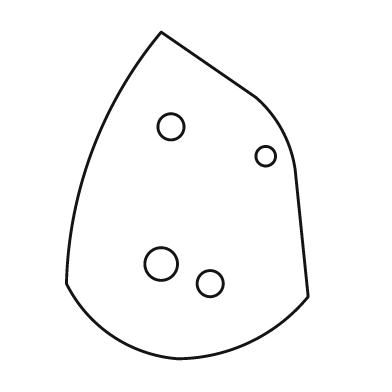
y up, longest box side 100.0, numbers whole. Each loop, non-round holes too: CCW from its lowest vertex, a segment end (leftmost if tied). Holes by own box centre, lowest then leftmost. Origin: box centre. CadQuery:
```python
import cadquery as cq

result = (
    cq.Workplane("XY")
    .moveTo(-3.0, -50.0)
    .threePointArc((19.0, -45.0), (37.0, -31.0))
    .lineTo(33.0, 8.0)
    .threePointArc((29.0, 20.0), (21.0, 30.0))
    .lineTo(-8.0, 50.0)
    .threePointArc((-29.0, 14.0), (-37.0, -27.0))
    .threePointArc((-23.0, -43.0), (-3.0, -50.0))
    .close()
    .moveTo(7.0, -27.0)
    .circle(4.0)
    .moveTo(-8.0, -21.0)
    .circle(5.0)
    .moveTo(24.0, 12.0)
    .circle(3.0)
    .moveTo(-5.0, 21.0)
    .circle(4.0)
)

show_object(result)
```